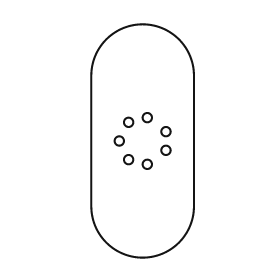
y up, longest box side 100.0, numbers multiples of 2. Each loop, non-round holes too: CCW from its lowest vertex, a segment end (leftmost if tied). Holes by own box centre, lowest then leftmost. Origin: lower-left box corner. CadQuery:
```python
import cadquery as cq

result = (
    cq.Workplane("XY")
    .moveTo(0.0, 22.0)
    .threePointArc((22.0, 0.0), (44.0, 22.0))
    .lineTo(44.0, 78.0)
    .threePointArc((22.0, 100.0), (0.0, 78.0))
    .close()
    .moveTo(24.0, 40.0)
    .circle(2.0)
    .moveTo(16.0, 42.0)
    .circle(2.0)
    .moveTo(32.0, 46.0)
    .circle(2.0)
    .moveTo(12.0, 50.0)
    .circle(2.0)
    .moveTo(32.0, 54.0)
    .circle(2.0)
    .moveTo(16.0, 58.0)
    .circle(2.0)
    .moveTo(24.0, 60.0)
    .circle(2.0)
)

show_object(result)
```